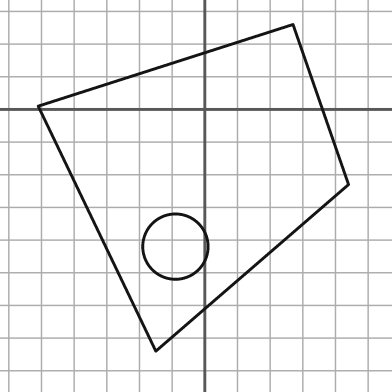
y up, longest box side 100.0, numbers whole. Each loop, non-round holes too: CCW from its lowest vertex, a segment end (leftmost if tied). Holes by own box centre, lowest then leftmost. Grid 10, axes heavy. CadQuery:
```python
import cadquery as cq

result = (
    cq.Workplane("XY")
    .moveTo(-15.0, -74.0)
    .lineTo(44.0, -23.0)
    .lineTo(27.0, 26.0)
    .lineTo(-51.0, 1.0)
    .close()
    .moveTo(-9.0, -42.0)
    .circle(10.0)
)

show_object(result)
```